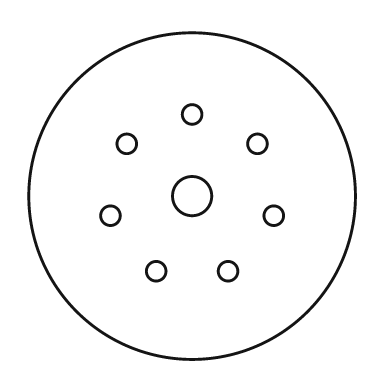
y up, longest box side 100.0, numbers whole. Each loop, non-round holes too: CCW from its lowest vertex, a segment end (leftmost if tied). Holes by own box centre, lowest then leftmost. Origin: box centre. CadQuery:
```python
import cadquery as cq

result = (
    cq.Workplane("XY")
    .moveTo(0.0, 0.0)
    .circle(50.0)
    .moveTo(-11.0, -23.0)
    .circle(3.0)
    .moveTo(11.0, -23.0)
    .circle(3.0)
    .moveTo(-25.0, -6.0)
    .circle(3.0)
    .moveTo(25.0, -6.0)
    .circle(3.0)
    .moveTo(0.0, 0.0)
    .circle(6.0)
    .moveTo(-20.0, 16.0)
    .circle(3.0)
    .moveTo(20.0, 16.0)
    .circle(3.0)
    .moveTo(0.0, 25.0)
    .circle(3.0)
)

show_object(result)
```